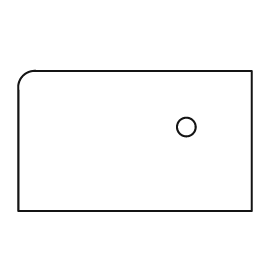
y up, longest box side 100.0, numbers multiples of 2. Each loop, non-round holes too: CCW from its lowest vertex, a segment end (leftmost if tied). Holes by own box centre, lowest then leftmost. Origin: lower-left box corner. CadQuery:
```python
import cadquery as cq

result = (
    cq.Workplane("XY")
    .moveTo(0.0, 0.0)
    .lineTo(100.0, 0.0)
    .lineTo(100.0, 60.0)
    .lineTo(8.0, 60.0)
    .threePointArc((2.0, 58.0), (0.0, 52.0))
    .close()
    .moveTo(72.0, 36.0)
    .circle(4.0)
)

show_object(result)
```